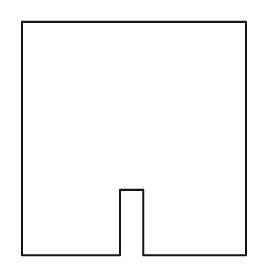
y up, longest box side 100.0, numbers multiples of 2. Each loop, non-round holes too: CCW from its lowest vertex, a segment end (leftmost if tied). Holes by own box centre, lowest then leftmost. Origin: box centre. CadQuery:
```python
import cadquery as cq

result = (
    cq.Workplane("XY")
    .moveTo(-48.0, -50.0)
    .lineTo(-6.0, -50.0)
    .lineTo(-6.0, -22.0)
    .lineTo(4.0, -22.0)
    .lineTo(4.0, -50.0)
    .lineTo(48.0, -50.0)
    .lineTo(48.0, 50.0)
    .lineTo(-48.0, 50.0)
    .close()
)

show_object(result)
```